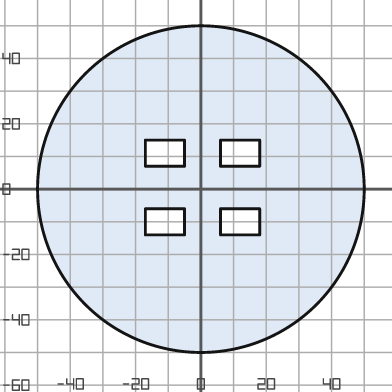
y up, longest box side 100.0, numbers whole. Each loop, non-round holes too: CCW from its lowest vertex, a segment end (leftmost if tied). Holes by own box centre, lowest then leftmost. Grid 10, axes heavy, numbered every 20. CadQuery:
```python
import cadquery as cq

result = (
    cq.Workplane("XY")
    .moveTo(0.0, 0.0)
    .circle(50.0)
    .moveTo(-17.0, -14.0)
    .lineTo(-5.0, -14.0)
    .lineTo(-5.0, -6.0)
    .lineTo(-17.0, -6.0)
    .close()
    .moveTo(6.0, -14.0)
    .lineTo(18.0, -14.0)
    .lineTo(18.0, -6.0)
    .lineTo(6.0, -6.0)
    .close()
    .moveTo(-17.0, 7.0)
    .lineTo(-5.0, 7.0)
    .lineTo(-5.0, 15.0)
    .lineTo(-17.0, 15.0)
    .close()
    .moveTo(6.0, 7.0)
    .lineTo(18.0, 7.0)
    .lineTo(18.0, 15.0)
    .lineTo(6.0, 15.0)
    .close()
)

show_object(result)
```